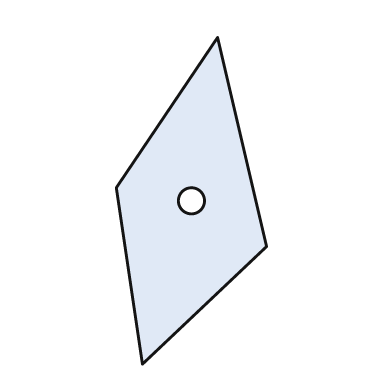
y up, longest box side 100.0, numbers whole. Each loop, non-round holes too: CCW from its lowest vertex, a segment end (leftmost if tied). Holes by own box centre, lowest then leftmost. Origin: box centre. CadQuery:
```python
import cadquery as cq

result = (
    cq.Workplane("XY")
    .moveTo(-15.0, -50.0)
    .lineTo(23.0, -14.0)
    .lineTo(8.0, 50.0)
    .lineTo(-23.0, 4.0)
    .close()
    .moveTo(0.0, 0.0)
    .circle(4.0)
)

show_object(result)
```